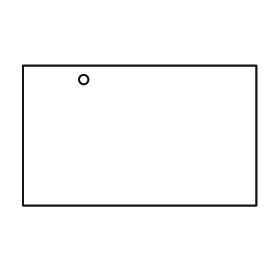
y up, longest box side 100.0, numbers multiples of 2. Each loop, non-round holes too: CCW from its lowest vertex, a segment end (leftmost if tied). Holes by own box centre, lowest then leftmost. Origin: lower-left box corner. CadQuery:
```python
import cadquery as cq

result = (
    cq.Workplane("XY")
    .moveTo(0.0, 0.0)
    .lineTo(100.0, 0.0)
    .lineTo(100.0, 60.0)
    .lineTo(0.0, 60.0)
    .close()
    .moveTo(26.0, 54.0)
    .circle(2.0)
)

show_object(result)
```